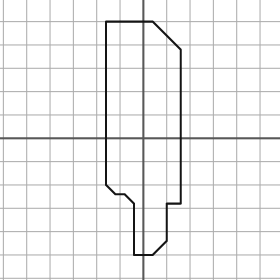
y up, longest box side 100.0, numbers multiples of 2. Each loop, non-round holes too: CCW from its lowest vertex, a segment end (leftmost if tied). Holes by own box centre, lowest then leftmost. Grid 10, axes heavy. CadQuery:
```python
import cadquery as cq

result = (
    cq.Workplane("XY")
    .moveTo(-4.0, -50.0)
    .lineTo(4.0, -50.0)
    .lineTo(10.0, -44.0)
    .lineTo(10.0, -28.0)
    .lineTo(16.0, -28.0)
    .lineTo(16.0, 38.0)
    .lineTo(4.0, 50.0)
    .lineTo(-16.0, 50.0)
    .lineTo(-16.0, -20.0)
    .lineTo(-12.0, -24.0)
    .lineTo(-8.0, -24.0)
    .lineTo(-4.0, -28.0)
    .close()
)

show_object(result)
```